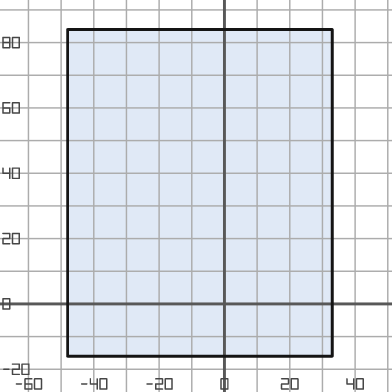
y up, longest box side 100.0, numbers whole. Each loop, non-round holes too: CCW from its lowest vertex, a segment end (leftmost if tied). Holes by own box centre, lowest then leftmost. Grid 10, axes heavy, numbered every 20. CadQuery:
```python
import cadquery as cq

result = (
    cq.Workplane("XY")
    .moveTo(-48.0, -16.0)
    .lineTo(33.0, -16.0)
    .lineTo(33.0, 84.0)
    .lineTo(-48.0, 84.0)
    .close()
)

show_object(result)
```